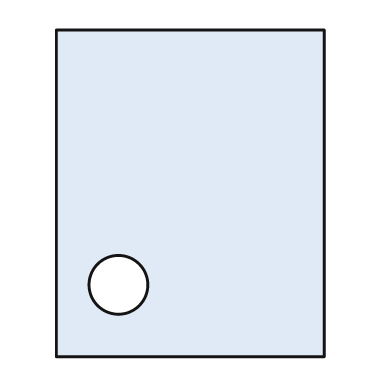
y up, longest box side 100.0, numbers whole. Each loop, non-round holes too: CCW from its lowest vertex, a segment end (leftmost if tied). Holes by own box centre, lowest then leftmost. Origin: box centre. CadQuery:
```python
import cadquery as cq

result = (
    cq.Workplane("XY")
    .moveTo(-41.0, -50.0)
    .lineTo(41.0, -50.0)
    .lineTo(41.0, 50.0)
    .lineTo(-41.0, 50.0)
    .close()
    .moveTo(-22.0, -28.0)
    .circle(9.0)
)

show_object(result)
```